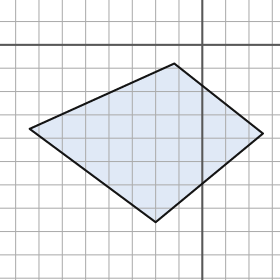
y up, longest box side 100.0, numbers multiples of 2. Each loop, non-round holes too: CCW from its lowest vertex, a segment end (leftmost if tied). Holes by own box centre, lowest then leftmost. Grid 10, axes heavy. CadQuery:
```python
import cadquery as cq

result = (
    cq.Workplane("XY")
    .moveTo(-20.0, -76.0)
    .lineTo(26.0, -38.0)
    .lineTo(-12.0, -8.0)
    .lineTo(-74.0, -36.0)
    .close()
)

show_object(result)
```